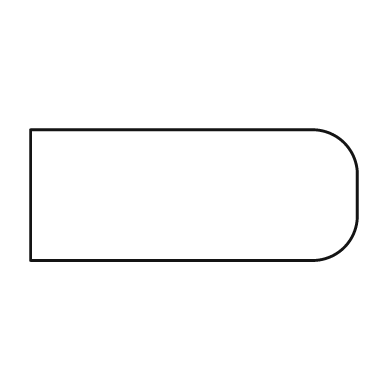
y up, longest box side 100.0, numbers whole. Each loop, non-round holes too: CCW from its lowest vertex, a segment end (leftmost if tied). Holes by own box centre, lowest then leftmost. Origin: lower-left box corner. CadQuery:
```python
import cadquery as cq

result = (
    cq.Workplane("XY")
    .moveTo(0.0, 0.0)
    .lineTo(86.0, 0.0)
    .threePointArc((96.0, 4.0), (100.0, 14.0))
    .lineTo(100.0, 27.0)
    .threePointArc((96.0, 36.0), (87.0, 40.0))
    .lineTo(0.0, 40.0)
    .close()
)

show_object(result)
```